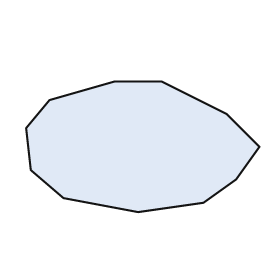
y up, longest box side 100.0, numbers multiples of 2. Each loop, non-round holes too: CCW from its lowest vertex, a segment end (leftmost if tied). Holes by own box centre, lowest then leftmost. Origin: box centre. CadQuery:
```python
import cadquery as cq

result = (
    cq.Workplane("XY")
    .moveTo(-2.0, -28.0)
    .lineTo(26.0, -24.0)
    .lineTo(40.0, -14.0)
    .lineTo(50.0, 0.0)
    .lineTo(36.0, 14.0)
    .lineTo(8.0, 28.0)
    .lineTo(-12.0, 28.0)
    .lineTo(-40.0, 20.0)
    .lineTo(-50.0, 8.0)
    .lineTo(-48.0, -10.0)
    .lineTo(-34.0, -22.0)
    .close()
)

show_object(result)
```